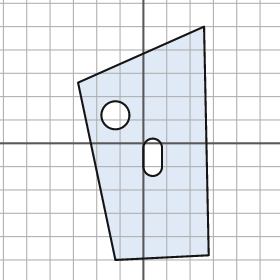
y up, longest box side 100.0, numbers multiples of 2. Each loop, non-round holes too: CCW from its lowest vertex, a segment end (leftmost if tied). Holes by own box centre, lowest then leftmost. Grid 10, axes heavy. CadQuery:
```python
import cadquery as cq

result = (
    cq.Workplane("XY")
    .moveTo(-12.0, -50.0)
    .lineTo(28.0, -48.0)
    .lineTo(26.0, 50.0)
    .lineTo(-28.0, 26.0)
    .close()
    .moveTo(0.0, -10.0)
    .threePointArc((4.0, -14.0), (8.0, -10.0))
    .lineTo(8.0, -2.0)
    .threePointArc((4.0, 2.0), (0.0, -2.0))
    .close()
    .moveTo(-12.0, 12.0)
    .circle(6.0)
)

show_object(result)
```